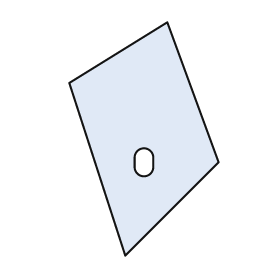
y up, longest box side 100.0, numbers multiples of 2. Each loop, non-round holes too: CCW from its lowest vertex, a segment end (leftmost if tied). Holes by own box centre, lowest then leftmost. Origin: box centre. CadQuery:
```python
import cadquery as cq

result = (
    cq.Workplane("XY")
    .moveTo(-8.0, -50.0)
    .lineTo(32.0, -10.0)
    .lineTo(10.0, 50.0)
    .lineTo(-32.0, 24.0)
    .close()
    .moveTo(-4.0, -12.0)
    .threePointArc((0.0, -16.0), (4.0, -12.0))
    .lineTo(4.0, -8.0)
    .threePointArc((0.0, -4.0), (-4.0, -8.0))
    .close()
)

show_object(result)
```